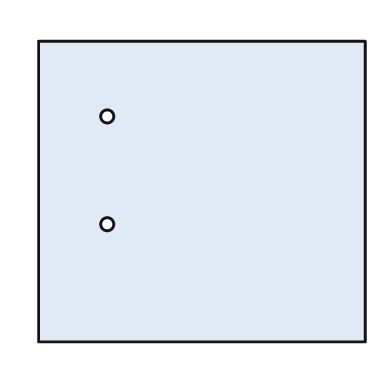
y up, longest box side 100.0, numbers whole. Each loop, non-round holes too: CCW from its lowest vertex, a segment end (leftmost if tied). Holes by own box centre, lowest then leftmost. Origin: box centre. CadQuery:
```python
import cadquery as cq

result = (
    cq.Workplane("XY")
    .moveTo(-50.0, -46.0)
    .lineTo(50.0, -46.0)
    .lineTo(50.0, 46.0)
    .lineTo(-50.0, 46.0)
    .close()
    .moveTo(-29.0, -10.0)
    .circle(2.0)
    .moveTo(-29.0, 23.0)
    .circle(2.0)
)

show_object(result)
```